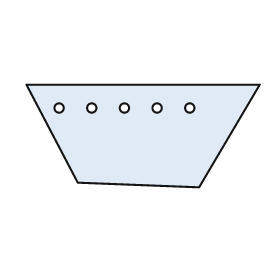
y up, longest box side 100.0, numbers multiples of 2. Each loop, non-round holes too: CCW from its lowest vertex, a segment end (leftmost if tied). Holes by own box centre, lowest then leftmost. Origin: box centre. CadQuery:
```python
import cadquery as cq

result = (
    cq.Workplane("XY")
    .moveTo(24.0, -22.0)
    .lineTo(50.0, 22.0)
    .lineTo(-50.0, 22.0)
    .lineTo(-28.0, -20.0)
    .close()
    .moveTo(-36.0, 12.0)
    .circle(2.0)
    .moveTo(-22.0, 12.0)
    .circle(2.0)
    .moveTo(-8.0, 12.0)
    .circle(2.0)
    .moveTo(6.0, 12.0)
    .circle(2.0)
    .moveTo(20.0, 12.0)
    .circle(2.0)
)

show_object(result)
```